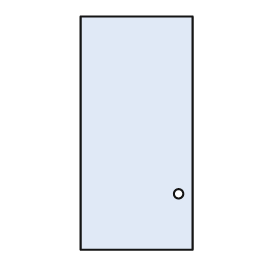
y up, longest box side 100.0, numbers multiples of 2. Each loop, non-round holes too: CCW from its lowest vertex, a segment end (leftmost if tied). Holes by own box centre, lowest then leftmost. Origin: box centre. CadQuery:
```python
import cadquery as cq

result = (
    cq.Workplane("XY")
    .moveTo(-24.0, -50.0)
    .lineTo(24.0, -50.0)
    .lineTo(24.0, 50.0)
    .lineTo(-24.0, 50.0)
    .close()
    .moveTo(18.0, -26.0)
    .circle(2.0)
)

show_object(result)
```